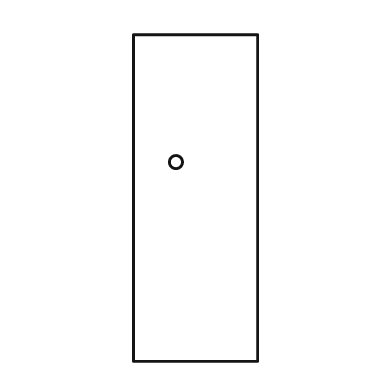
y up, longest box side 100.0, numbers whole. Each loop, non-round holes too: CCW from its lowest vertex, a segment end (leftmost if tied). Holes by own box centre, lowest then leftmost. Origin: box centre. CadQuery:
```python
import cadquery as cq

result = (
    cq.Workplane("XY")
    .moveTo(-19.0, -50.0)
    .lineTo(19.0, -50.0)
    .lineTo(19.0, 50.0)
    .lineTo(-19.0, 50.0)
    .close()
    .moveTo(-6.0, 11.0)
    .circle(2.0)
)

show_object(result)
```